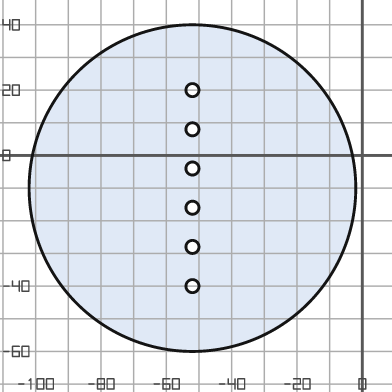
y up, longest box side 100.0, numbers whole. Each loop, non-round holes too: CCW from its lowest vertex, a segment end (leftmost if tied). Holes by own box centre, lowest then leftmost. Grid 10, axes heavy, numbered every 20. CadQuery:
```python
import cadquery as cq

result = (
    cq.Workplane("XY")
    .moveTo(-52.0, -10.0)
    .circle(50.0)
    .moveTo(-52.0, -40.0)
    .circle(2.0)
    .moveTo(-52.0, -28.0)
    .circle(2.0)
    .moveTo(-52.0, -16.0)
    .circle(2.0)
    .moveTo(-52.0, -4.0)
    .circle(2.0)
    .moveTo(-52.0, 8.0)
    .circle(2.0)
    .moveTo(-52.0, 20.0)
    .circle(2.0)
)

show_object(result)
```